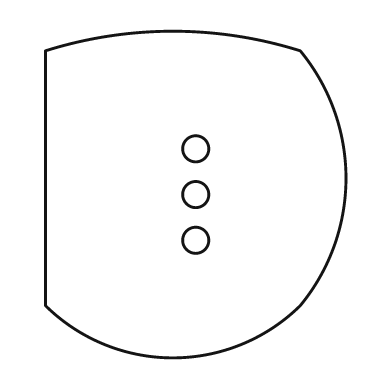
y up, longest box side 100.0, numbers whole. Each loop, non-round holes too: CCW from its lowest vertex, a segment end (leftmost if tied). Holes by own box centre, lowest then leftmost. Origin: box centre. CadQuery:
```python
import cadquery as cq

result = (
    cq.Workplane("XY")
    .moveTo(-46.0, -34.0)
    .threePointArc((-7.0, -50.0), (32.0, -34.0))
    .threePointArc((46.0, 5.0), (32.0, 44.0))
    .threePointArc((-7.0, 50.0), (-46.0, 44.0))
    .close()
    .moveTo(0.0, -14.0)
    .circle(4.0)
    .moveTo(0.0, 0.0)
    .circle(4.0)
    .moveTo(0.0, 14.0)
    .circle(4.0)
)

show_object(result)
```